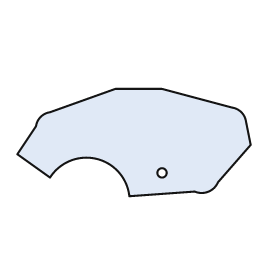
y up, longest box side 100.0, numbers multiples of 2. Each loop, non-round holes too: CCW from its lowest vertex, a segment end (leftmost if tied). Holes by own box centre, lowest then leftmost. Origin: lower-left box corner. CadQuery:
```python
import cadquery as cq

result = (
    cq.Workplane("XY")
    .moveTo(48.0, 0.0)
    .lineTo(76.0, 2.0)
    .threePointArc((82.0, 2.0), (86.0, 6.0))
    .lineTo(100.0, 22.0)
    .lineTo(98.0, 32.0)
    .threePointArc((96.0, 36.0), (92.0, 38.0))
    .lineTo(62.0, 46.0)
    .lineTo(42.0, 46.0)
    .lineTo(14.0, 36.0)
    .threePointArc((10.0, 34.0), (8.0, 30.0))
    .lineTo(0.0, 18.0)
    .lineTo(14.0, 8.0)
    .threePointArc((34.0, 16.0), (48.0, 0.0))
    .close()
    .moveTo(62.0, 10.0)
    .circle(2.0)
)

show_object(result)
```